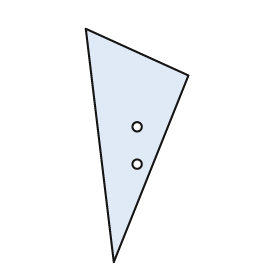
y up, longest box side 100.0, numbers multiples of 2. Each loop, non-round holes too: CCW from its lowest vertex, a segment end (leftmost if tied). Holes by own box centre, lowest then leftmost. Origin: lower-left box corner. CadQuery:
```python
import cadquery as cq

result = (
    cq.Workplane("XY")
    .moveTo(12.0, 0.0)
    .lineTo(44.0, 80.0)
    .lineTo(0.0, 100.0)
    .close()
    .moveTo(22.0, 42.0)
    .circle(2.0)
    .moveTo(22.0, 58.0)
    .circle(2.0)
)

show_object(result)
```